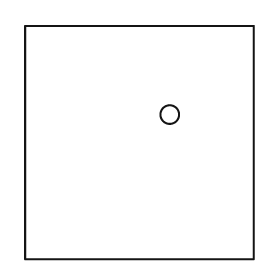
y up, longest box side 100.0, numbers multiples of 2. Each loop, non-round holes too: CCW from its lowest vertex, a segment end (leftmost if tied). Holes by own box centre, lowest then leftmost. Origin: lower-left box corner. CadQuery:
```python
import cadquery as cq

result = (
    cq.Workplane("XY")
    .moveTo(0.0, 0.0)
    .lineTo(98.0, 0.0)
    .lineTo(98.0, 100.0)
    .lineTo(0.0, 100.0)
    .close()
    .moveTo(62.0, 62.0)
    .circle(4.0)
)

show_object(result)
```